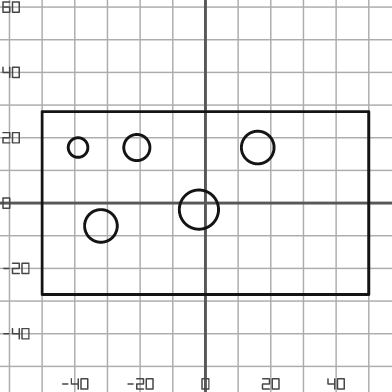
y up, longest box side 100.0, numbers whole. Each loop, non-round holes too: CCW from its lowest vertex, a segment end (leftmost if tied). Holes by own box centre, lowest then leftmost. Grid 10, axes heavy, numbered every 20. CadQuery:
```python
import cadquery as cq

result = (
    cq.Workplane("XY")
    .moveTo(-50.0, -28.0)
    .lineTo(50.0, -28.0)
    .lineTo(50.0, 28.0)
    .lineTo(-50.0, 28.0)
    .close()
    .moveTo(-32.0, -7.0)
    .circle(5.0)
    .moveTo(-2.0, -2.0)
    .circle(6.0)
    .moveTo(-39.0, 17.0)
    .circle(3.0)
    .moveTo(-21.0, 17.0)
    .circle(4.0)
    .moveTo(16.0, 17.0)
    .circle(5.0)
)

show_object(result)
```